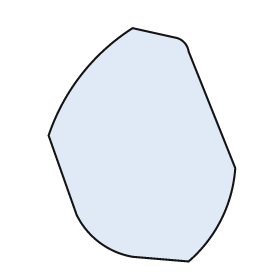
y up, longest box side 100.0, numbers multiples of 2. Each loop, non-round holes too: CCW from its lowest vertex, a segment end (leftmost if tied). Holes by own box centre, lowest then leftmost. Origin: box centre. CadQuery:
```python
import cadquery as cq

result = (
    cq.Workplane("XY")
    .moveTo(20.0, -50.0)
    .threePointArc((34.0, -32.0), (40.0, -10.0))
    .lineTo(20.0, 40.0)
    .threePointArc((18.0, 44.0), (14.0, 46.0))
    .lineTo(-4.0, 50.0)
    .threePointArc((-26.0, 30.0), (-40.0, 4.0))
    .lineTo(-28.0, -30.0)
    .threePointArc((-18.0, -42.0), (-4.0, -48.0))
    .close()
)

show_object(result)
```